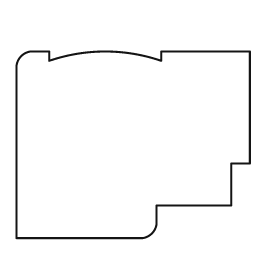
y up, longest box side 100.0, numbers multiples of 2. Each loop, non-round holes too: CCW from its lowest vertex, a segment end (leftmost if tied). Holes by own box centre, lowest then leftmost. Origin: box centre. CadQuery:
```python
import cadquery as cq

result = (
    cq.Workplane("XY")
    .moveTo(-50.0, -40.0)
    .lineTo(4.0, -40.0)
    .threePointArc((8.0, -38.0), (10.0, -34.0))
    .lineTo(10.0, -26.0)
    .lineTo(42.0, -26.0)
    .lineTo(42.0, -8.0)
    .lineTo(50.0, -8.0)
    .lineTo(50.0, 40.0)
    .lineTo(12.0, 40.0)
    .lineTo(12.0, 36.0)
    .threePointArc((-12.0, 40.0), (-36.0, 36.0))
    .lineTo(-36.0, 40.0)
    .lineTo(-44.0, 40.0)
    .threePointArc((-48.0, 38.0), (-50.0, 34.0))
    .close()
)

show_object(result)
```